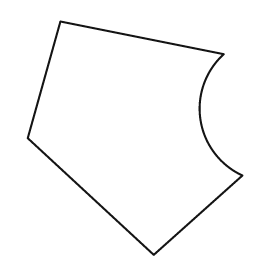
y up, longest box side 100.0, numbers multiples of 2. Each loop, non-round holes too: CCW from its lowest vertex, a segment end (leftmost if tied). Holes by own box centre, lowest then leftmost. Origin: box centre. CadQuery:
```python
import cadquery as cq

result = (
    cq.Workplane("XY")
    .moveTo(8.0, -50.0)
    .lineTo(46.0, -16.0)
    .threePointArc((28.0, 8.0), (38.0, 36.0))
    .lineTo(-32.0, 50.0)
    .lineTo(-46.0, 0.0)
    .close()
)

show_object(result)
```